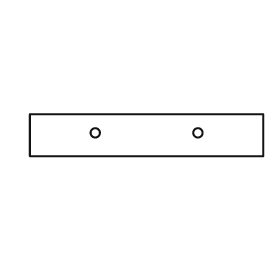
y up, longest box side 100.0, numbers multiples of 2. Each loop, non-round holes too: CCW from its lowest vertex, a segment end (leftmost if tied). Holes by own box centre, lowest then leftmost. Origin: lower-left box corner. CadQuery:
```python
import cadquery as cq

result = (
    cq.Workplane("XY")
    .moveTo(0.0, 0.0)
    .lineTo(100.0, 0.0)
    .lineTo(100.0, 18.0)
    .lineTo(0.0, 18.0)
    .close()
    .moveTo(28.0, 10.0)
    .circle(2.0)
    .moveTo(72.0, 10.0)
    .circle(2.0)
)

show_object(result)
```